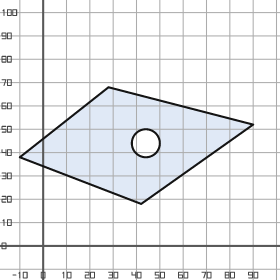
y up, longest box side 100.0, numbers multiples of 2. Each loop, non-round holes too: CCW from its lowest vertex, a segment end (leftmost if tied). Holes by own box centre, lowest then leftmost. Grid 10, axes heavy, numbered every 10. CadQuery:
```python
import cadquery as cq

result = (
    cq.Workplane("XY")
    .moveTo(42.0, 18.0)
    .lineTo(90.0, 52.0)
    .lineTo(28.0, 68.0)
    .lineTo(-10.0, 38.0)
    .close()
    .moveTo(44.0, 44.0)
    .circle(6.0)
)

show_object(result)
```